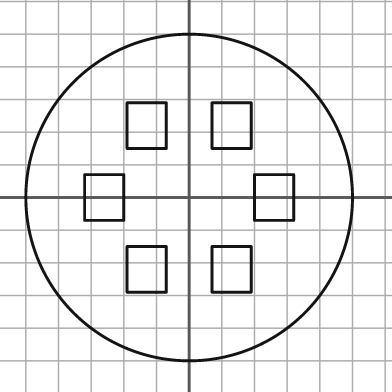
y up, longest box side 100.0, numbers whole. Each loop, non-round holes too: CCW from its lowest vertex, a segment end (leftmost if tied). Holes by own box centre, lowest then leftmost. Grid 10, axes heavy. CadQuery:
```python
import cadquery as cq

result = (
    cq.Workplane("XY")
    .moveTo(0.0, 0.0)
    .circle(50.0)
    .moveTo(-19.0, -29.0)
    .lineTo(-7.0, -29.0)
    .lineTo(-7.0, -15.0)
    .lineTo(-19.0, -15.0)
    .close()
    .moveTo(7.0, -29.0)
    .lineTo(19.0, -29.0)
    .lineTo(19.0, -15.0)
    .lineTo(7.0, -15.0)
    .close()
    .moveTo(-32.0, -7.0)
    .lineTo(-20.0, -7.0)
    .lineTo(-20.0, 7.0)
    .lineTo(-32.0, 7.0)
    .close()
    .moveTo(20.0, -7.0)
    .lineTo(32.0, -7.0)
    .lineTo(32.0, 7.0)
    .lineTo(20.0, 7.0)
    .close()
    .moveTo(-19.0, 15.0)
    .lineTo(-7.0, 15.0)
    .lineTo(-7.0, 29.0)
    .lineTo(-19.0, 29.0)
    .close()
    .moveTo(7.0, 15.0)
    .lineTo(19.0, 15.0)
    .lineTo(19.0, 29.0)
    .lineTo(7.0, 29.0)
    .close()
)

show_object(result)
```